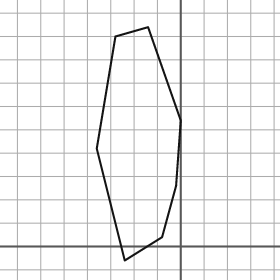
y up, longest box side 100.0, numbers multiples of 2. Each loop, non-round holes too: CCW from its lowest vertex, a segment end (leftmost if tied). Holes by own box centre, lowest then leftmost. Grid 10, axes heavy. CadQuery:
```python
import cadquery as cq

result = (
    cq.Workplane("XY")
    .moveTo(-24.0, -6.0)
    .lineTo(-8.0, 4.0)
    .lineTo(-2.0, 26.0)
    .lineTo(0.0, 54.0)
    .lineTo(-14.0, 94.0)
    .lineTo(-28.0, 90.0)
    .lineTo(-36.0, 42.0)
    .close()
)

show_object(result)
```